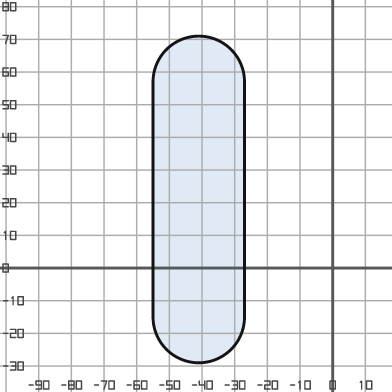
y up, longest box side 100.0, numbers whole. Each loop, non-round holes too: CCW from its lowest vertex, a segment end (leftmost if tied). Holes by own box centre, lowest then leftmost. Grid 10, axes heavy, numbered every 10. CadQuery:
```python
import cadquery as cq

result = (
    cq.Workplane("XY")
    .moveTo(-55.0, -15.0)
    .threePointArc((-41.0, -29.0), (-27.0, -15.0))
    .lineTo(-27.0, 57.0)
    .threePointArc((-41.0, 71.0), (-55.0, 57.0))
    .close()
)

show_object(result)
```